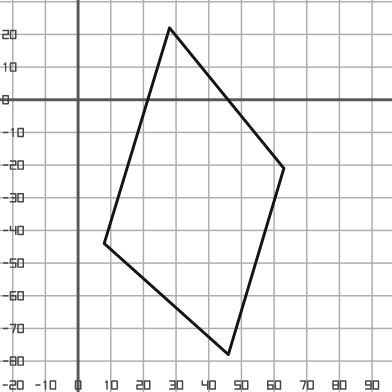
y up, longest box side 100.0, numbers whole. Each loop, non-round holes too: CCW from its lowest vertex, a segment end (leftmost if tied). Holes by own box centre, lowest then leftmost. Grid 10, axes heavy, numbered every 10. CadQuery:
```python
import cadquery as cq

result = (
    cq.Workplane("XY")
    .moveTo(46.0, -78.0)
    .lineTo(63.0, -21.0)
    .lineTo(28.0, 22.0)
    .lineTo(8.0, -44.0)
    .close()
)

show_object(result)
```